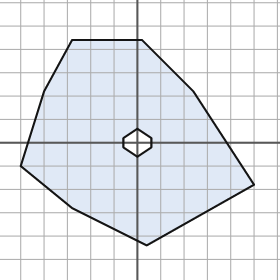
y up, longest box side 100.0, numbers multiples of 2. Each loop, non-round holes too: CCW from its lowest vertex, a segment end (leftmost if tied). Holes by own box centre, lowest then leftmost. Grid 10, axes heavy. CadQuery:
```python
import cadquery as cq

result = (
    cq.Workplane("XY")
    .moveTo(4.0, -44.0)
    .lineTo(50.0, -18.0)
    .lineTo(24.0, 22.0)
    .lineTo(2.0, 44.0)
    .lineTo(-28.0, 44.0)
    .lineTo(-40.0, 22.0)
    .lineTo(-50.0, -10.0)
    .lineTo(-28.0, -28.0)
    .close()
    .moveTo(0.0, -6.0)
    .lineTo(6.0, -2.0)
    .lineTo(6.0, 2.0)
    .lineTo(0.0, 6.0)
    .lineTo(-6.0, 2.0)
    .lineTo(-6.0, -2.0)
    .close()
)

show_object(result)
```